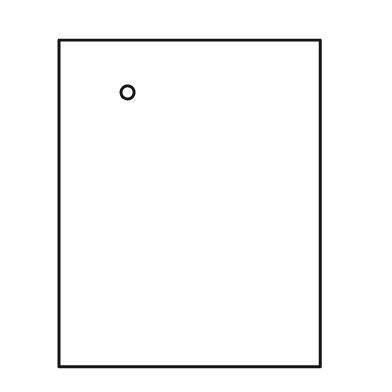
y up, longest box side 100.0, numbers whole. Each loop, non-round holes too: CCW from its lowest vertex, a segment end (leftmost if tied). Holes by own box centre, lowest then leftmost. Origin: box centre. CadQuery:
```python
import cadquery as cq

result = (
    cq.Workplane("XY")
    .moveTo(-40.0, -50.0)
    .lineTo(40.0, -50.0)
    .lineTo(40.0, 50.0)
    .lineTo(-40.0, 50.0)
    .close()
    .moveTo(-19.0, 34.0)
    .circle(2.0)
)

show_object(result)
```